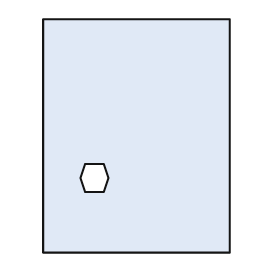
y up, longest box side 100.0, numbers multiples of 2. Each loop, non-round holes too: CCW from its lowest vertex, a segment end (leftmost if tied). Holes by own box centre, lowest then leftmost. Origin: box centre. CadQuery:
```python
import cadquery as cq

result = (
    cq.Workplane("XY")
    .moveTo(-40.0, -50.0)
    .lineTo(40.0, -50.0)
    .lineTo(40.0, 50.0)
    .lineTo(-40.0, 50.0)
    .close()
    .moveTo(-22.0, -24.0)
    .lineTo(-14.0, -24.0)
    .lineTo(-12.0, -18.0)
    .lineTo(-14.0, -12.0)
    .lineTo(-22.0, -12.0)
    .lineTo(-24.0, -18.0)
    .close()
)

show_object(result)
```